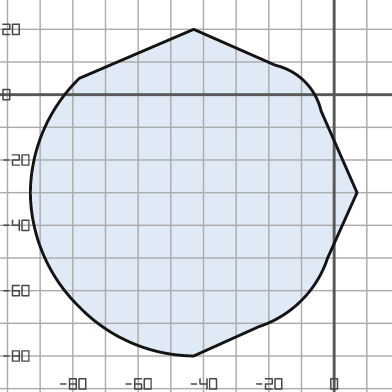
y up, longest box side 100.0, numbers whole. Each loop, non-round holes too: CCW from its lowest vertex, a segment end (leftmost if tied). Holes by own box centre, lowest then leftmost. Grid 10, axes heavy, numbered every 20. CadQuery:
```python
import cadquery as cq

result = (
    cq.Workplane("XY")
    .moveTo(-43.0, -80.0)
    .lineTo(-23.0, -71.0)
    .threePointArc((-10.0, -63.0), (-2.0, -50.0))
    .lineTo(7.0, -30.0)
    .lineTo(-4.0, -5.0)
    .threePointArc((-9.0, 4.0), (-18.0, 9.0))
    .lineTo(-43.0, 20.0)
    .lineTo(-78.0, 5.0)
    .threePointArc((-89.0, -11.0), (-93.0, -30.0))
    .threePointArc((-89.0, -49.0), (-78.0, -65.0))
    .threePointArc((-62.0, -76.0), (-43.0, -80.0))
    .close()
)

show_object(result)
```